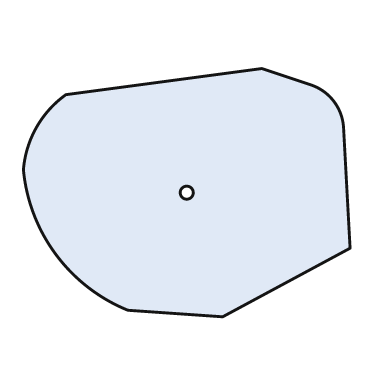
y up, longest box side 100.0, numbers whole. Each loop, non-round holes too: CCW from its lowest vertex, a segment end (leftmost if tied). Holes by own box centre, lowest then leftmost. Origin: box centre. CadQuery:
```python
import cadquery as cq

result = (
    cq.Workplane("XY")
    .moveTo(11.0, -38.0)
    .lineTo(50.0, -17.0)
    .lineTo(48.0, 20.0)
    .threePointArc((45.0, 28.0), (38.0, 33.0))
    .lineTo(23.0, 38.0)
    .lineTo(-37.0, 30.0)
    .threePointArc((-46.0, 20.0), (-50.0, 7.0))
    .threePointArc((-40.0, -19.0), (-18.0, -36.0))
    .close()
    .moveTo(0.0, 0.0)
    .circle(2.0)
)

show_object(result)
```